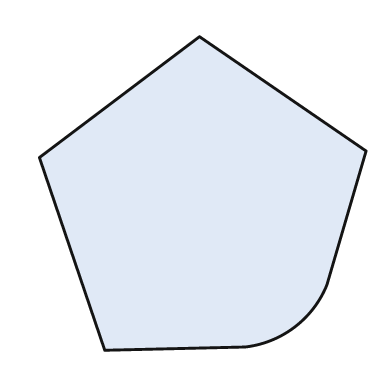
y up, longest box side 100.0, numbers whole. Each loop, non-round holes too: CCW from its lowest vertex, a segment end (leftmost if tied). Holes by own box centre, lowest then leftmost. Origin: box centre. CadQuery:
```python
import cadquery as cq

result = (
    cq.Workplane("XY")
    .moveTo(-30.0, -48.0)
    .lineTo(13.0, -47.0)
    .threePointArc((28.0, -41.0), (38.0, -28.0))
    .lineTo(50.0, 13.0)
    .lineTo(-1.0, 48.0)
    .lineTo(-50.0, 11.0)
    .close()
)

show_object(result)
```